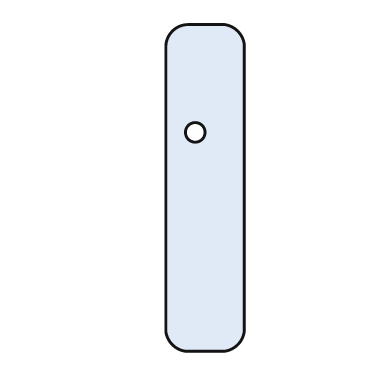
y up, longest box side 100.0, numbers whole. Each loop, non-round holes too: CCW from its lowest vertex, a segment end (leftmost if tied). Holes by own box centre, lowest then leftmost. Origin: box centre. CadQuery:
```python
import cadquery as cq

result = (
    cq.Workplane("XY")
    .moveTo(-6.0, -50.0)
    .lineTo(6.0, -50.0)
    .threePointArc((10.0, -48.0), (12.0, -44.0))
    .lineTo(12.0, 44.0)
    .threePointArc((10.0, 48.0), (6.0, 50.0))
    .lineTo(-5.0, 50.0)
    .threePointArc((-10.0, 48.0), (-12.0, 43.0))
    .lineTo(-12.0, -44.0)
    .threePointArc((-10.0, -48.0), (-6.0, -50.0))
    .close()
    .moveTo(-3.0, 17.0)
    .circle(3.0)
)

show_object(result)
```